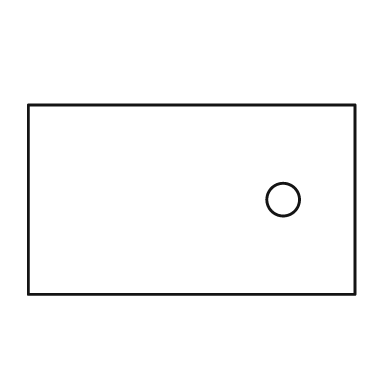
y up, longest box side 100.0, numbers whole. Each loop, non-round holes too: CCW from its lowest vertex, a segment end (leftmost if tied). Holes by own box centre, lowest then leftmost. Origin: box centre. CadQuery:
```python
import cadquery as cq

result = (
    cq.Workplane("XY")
    .moveTo(-50.0, -29.0)
    .lineTo(50.0, -29.0)
    .lineTo(50.0, 29.0)
    .lineTo(-50.0, 29.0)
    .close()
    .moveTo(28.0, 0.0)
    .circle(5.0)
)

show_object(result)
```